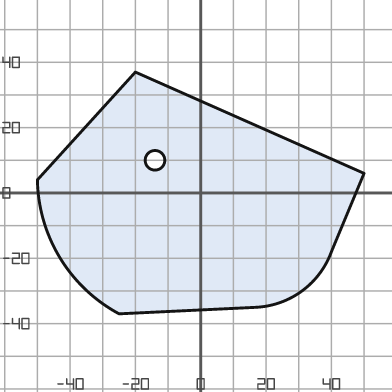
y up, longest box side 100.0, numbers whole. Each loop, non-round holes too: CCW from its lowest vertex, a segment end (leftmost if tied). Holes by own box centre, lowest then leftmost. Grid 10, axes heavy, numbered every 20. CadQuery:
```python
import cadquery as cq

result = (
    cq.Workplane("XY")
    .moveTo(-25.0, -37.0)
    .lineTo(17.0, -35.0)
    .threePointArc((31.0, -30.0), (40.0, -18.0))
    .lineTo(50.0, 6.0)
    .lineTo(-20.0, 37.0)
    .lineTo(-50.0, 4.0)
    .threePointArc((-43.0, -20.0), (-25.0, -37.0))
    .close()
    .moveTo(-14.0, 10.0)
    .circle(3.0)
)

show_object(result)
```